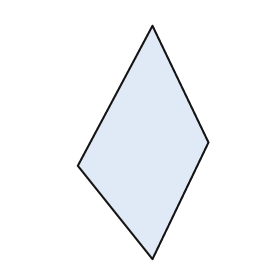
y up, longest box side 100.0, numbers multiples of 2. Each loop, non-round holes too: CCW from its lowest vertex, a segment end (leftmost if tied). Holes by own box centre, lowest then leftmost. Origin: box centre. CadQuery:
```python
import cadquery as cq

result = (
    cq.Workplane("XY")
    .moveTo(4.0, -50.0)
    .lineTo(28.0, 0.0)
    .lineTo(4.0, 50.0)
    .lineTo(-28.0, -10.0)
    .close()
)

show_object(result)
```